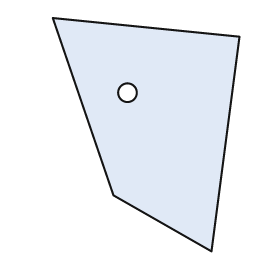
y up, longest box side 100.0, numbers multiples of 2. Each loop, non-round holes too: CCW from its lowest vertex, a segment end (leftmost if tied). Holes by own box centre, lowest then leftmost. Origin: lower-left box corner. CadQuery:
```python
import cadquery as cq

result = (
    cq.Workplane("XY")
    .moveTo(68.0, 0.0)
    .lineTo(80.0, 92.0)
    .lineTo(0.0, 100.0)
    .lineTo(26.0, 24.0)
    .close()
    .moveTo(32.0, 68.0)
    .circle(4.0)
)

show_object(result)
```